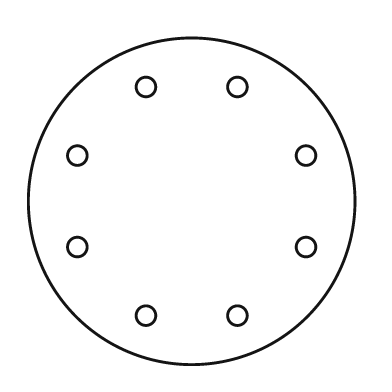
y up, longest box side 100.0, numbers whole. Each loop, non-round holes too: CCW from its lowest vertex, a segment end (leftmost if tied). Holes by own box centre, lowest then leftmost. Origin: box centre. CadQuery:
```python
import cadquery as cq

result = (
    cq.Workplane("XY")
    .moveTo(0.0, 0.0)
    .circle(50.0)
    .moveTo(-14.0, -35.0)
    .circle(3.0)
    .moveTo(14.0, -35.0)
    .circle(3.0)
    .moveTo(-35.0, -14.0)
    .circle(3.0)
    .moveTo(35.0, -14.0)
    .circle(3.0)
    .moveTo(-35.0, 14.0)
    .circle(3.0)
    .moveTo(35.0, 14.0)
    .circle(3.0)
    .moveTo(-14.0, 35.0)
    .circle(3.0)
    .moveTo(14.0, 35.0)
    .circle(3.0)
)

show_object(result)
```